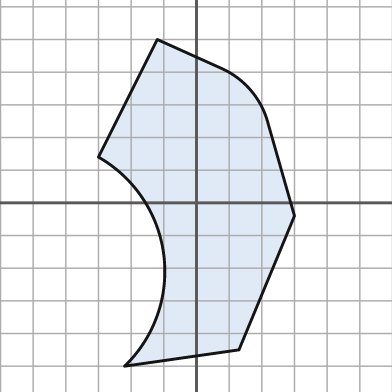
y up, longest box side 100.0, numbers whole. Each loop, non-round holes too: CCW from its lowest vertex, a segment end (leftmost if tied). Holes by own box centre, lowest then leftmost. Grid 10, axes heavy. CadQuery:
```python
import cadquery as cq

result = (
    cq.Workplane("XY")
    .moveTo(-22.0, -50.0)
    .lineTo(13.0, -45.0)
    .lineTo(30.0, -4.0)
    .lineTo(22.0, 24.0)
    .threePointArc((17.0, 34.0), (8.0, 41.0))
    .lineTo(-12.0, 50.0)
    .lineTo(-30.0, 14.0)
    .threePointArc((-10.0, -16.0), (-22.0, -50.0))
    .close()
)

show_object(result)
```